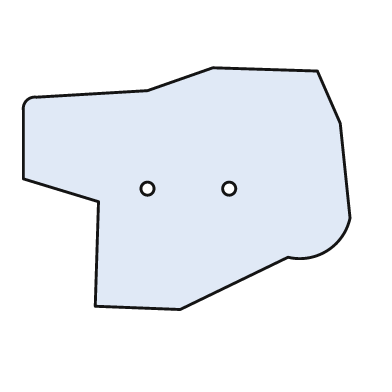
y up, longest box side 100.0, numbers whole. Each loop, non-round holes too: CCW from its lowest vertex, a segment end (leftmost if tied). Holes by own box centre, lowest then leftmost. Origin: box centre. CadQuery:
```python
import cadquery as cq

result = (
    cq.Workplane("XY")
    .moveTo(-2.0, -37.0)
    .lineTo(31.0, -21.0)
    .threePointArc((43.0, -19.0), (50.0, -9.0))
    .lineTo(47.0, 20.0)
    .lineTo(40.0, 36.0)
    .lineTo(8.0, 37.0)
    .lineTo(-12.0, 30.0)
    .lineTo(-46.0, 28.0)
    .threePointArc((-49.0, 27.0), (-50.0, 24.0))
    .lineTo(-50.0, 3.0)
    .lineTo(-27.0, -4.0)
    .lineTo(-28.0, -36.0)
    .close()
    .moveTo(-12.0, 0.0)
    .circle(2.0)
    .moveTo(13.0, 0.0)
    .circle(2.0)
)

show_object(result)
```